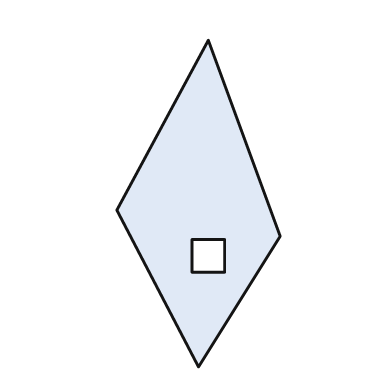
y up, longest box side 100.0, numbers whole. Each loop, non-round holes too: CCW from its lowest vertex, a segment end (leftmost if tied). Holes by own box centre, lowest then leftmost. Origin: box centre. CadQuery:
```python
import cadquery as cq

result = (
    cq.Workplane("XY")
    .moveTo(0.0, -50.0)
    .lineTo(25.0, -10.0)
    .lineTo(3.0, 50.0)
    .lineTo(-25.0, -2.0)
    .close()
    .moveTo(-2.0, -21.0)
    .lineTo(8.0, -21.0)
    .lineTo(8.0, -11.0)
    .lineTo(-2.0, -11.0)
    .close()
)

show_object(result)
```